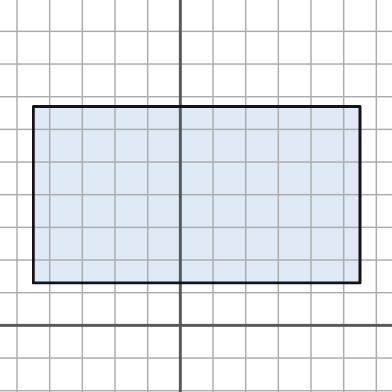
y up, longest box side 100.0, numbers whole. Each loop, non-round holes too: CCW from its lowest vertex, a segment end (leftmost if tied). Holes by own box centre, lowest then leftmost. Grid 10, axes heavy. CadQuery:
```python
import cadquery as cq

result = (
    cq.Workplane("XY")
    .moveTo(-45.0, 13.0)
    .lineTo(55.0, 13.0)
    .lineTo(55.0, 67.0)
    .lineTo(-45.0, 67.0)
    .close()
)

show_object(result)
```